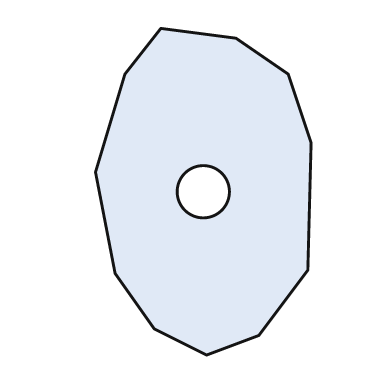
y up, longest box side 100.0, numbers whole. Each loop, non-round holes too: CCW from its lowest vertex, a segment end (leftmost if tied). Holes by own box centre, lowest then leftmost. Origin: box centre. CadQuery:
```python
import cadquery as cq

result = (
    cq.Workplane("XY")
    .moveTo(1.0, -50.0)
    .lineTo(17.0, -44.0)
    .lineTo(32.0, -24.0)
    .lineTo(33.0, 15.0)
    .lineTo(26.0, 36.0)
    .lineTo(10.0, 47.0)
    .lineTo(-13.0, 50.0)
    .lineTo(-24.0, 36.0)
    .lineTo(-33.0, 6.0)
    .lineTo(-27.0, -25.0)
    .lineTo(-15.0, -42.0)
    .close()
    .moveTo(0.0, 0.0)
    .circle(8.0)
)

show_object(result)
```